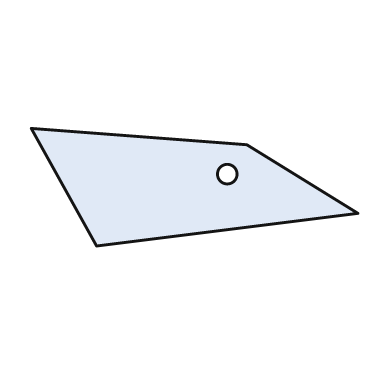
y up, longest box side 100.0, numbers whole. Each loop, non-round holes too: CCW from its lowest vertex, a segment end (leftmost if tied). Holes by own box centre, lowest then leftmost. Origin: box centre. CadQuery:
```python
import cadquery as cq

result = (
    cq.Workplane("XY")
    .moveTo(-30.0, -18.0)
    .lineTo(50.0, -8.0)
    .lineTo(16.0, 13.0)
    .lineTo(-50.0, 18.0)
    .close()
    .moveTo(10.0, 4.0)
    .circle(3.0)
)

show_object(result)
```